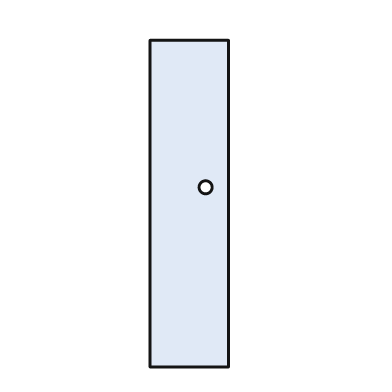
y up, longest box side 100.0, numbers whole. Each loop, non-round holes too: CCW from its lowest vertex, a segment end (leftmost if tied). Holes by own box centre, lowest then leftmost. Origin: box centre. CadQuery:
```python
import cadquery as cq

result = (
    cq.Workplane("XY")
    .moveTo(-12.0, -50.0)
    .lineTo(12.0, -50.0)
    .lineTo(12.0, 50.0)
    .lineTo(-12.0, 50.0)
    .close()
    .moveTo(5.0, 5.0)
    .circle(2.0)
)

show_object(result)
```